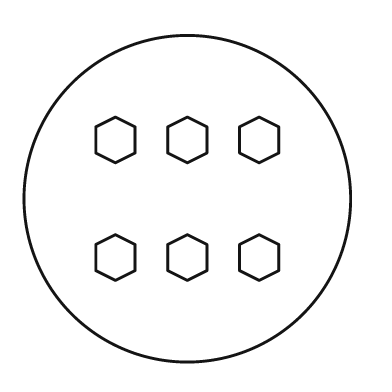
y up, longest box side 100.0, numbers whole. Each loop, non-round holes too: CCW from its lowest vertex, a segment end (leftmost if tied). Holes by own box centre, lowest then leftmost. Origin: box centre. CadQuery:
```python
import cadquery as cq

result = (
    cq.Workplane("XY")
    .moveTo(0.0, 0.0)
    .circle(50.0)
    .moveTo(-22.0, -25.0)
    .lineTo(-16.0, -22.0)
    .lineTo(-16.0, -14.0)
    .lineTo(-22.0, -11.0)
    .lineTo(-28.0, -14.0)
    .lineTo(-28.0, -22.0)
    .close()
    .moveTo(0.0, -25.0)
    .lineTo(6.0, -22.0)
    .lineTo(6.0, -14.0)
    .lineTo(0.0, -11.0)
    .lineTo(-6.0, -14.0)
    .lineTo(-6.0, -22.0)
    .close()
    .moveTo(22.0, -25.0)
    .lineTo(28.0, -22.0)
    .lineTo(28.0, -14.0)
    .lineTo(22.0, -11.0)
    .lineTo(16.0, -14.0)
    .lineTo(16.0, -22.0)
    .close()
    .moveTo(-22.0, 11.0)
    .lineTo(-16.0, 14.0)
    .lineTo(-16.0, 22.0)
    .lineTo(-22.0, 25.0)
    .lineTo(-28.0, 22.0)
    .lineTo(-28.0, 14.0)
    .close()
    .moveTo(0.0, 11.0)
    .lineTo(6.0, 14.0)
    .lineTo(6.0, 22.0)
    .lineTo(0.0, 25.0)
    .lineTo(-6.0, 22.0)
    .lineTo(-6.0, 14.0)
    .close()
    .moveTo(22.0, 11.0)
    .lineTo(28.0, 14.0)
    .lineTo(28.0, 22.0)
    .lineTo(22.0, 25.0)
    .lineTo(16.0, 22.0)
    .lineTo(16.0, 14.0)
    .close()
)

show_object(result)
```